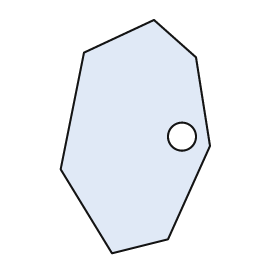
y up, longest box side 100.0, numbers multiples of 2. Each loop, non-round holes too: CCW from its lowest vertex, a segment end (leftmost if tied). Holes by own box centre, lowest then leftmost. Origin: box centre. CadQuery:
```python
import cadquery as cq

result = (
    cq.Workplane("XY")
    .moveTo(-10.0, -50.0)
    .lineTo(14.0, -44.0)
    .lineTo(32.0, -4.0)
    .lineTo(26.0, 34.0)
    .lineTo(8.0, 50.0)
    .lineTo(-22.0, 36.0)
    .lineTo(-32.0, -14.0)
    .close()
    .moveTo(20.0, 0.0)
    .circle(6.0)
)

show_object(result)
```